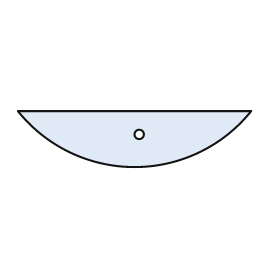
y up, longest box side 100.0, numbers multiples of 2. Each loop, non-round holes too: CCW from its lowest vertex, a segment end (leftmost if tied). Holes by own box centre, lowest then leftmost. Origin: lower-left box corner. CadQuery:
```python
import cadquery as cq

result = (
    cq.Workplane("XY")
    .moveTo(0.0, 24.0)
    .threePointArc((50.0, 0.0), (100.0, 24.0))
    .close()
    .moveTo(52.0, 14.0)
    .circle(2.0)
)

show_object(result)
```